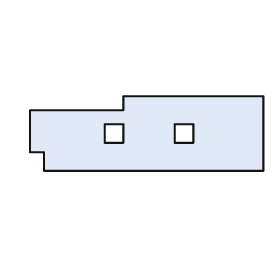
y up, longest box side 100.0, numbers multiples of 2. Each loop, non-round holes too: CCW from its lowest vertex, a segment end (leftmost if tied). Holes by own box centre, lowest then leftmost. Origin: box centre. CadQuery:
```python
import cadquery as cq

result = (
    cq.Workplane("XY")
    .moveTo(-44.0, -16.0)
    .lineTo(50.0, -16.0)
    .lineTo(50.0, 16.0)
    .lineTo(-10.0, 16.0)
    .lineTo(-10.0, 10.0)
    .lineTo(-50.0, 10.0)
    .lineTo(-50.0, -8.0)
    .lineTo(-44.0, -8.0)
    .close()
    .moveTo(-18.0, -4.0)
    .lineTo(-10.0, -4.0)
    .lineTo(-10.0, 4.0)
    .lineTo(-18.0, 4.0)
    .close()
    .moveTo(12.0, -4.0)
    .lineTo(20.0, -4.0)
    .lineTo(20.0, 4.0)
    .lineTo(12.0, 4.0)
    .close()
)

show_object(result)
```